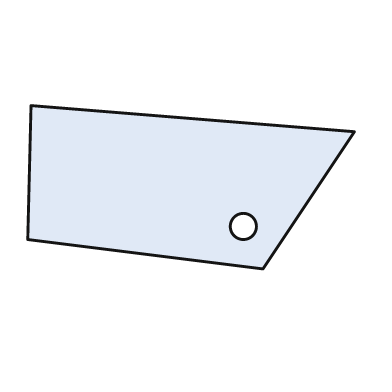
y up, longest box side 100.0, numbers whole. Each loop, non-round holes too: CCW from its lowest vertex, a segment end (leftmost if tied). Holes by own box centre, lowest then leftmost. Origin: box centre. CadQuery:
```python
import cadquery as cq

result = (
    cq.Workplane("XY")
    .moveTo(22.0, -25.0)
    .lineTo(50.0, 17.0)
    .lineTo(-49.0, 25.0)
    .lineTo(-50.0, -16.0)
    .close()
    .moveTo(16.0, -12.0)
    .circle(4.0)
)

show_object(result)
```